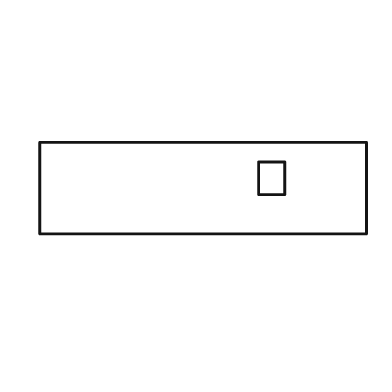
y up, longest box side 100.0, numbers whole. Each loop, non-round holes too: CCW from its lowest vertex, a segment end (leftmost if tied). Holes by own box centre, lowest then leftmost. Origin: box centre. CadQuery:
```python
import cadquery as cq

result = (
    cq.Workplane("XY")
    .moveTo(-50.0, -14.0)
    .lineTo(50.0, -14.0)
    .lineTo(50.0, 14.0)
    .lineTo(-50.0, 14.0)
    .close()
    .moveTo(17.0, -2.0)
    .lineTo(25.0, -2.0)
    .lineTo(25.0, 8.0)
    .lineTo(17.0, 8.0)
    .close()
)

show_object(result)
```